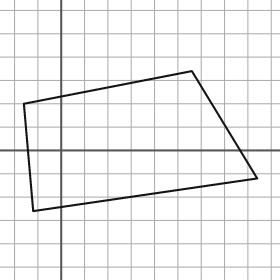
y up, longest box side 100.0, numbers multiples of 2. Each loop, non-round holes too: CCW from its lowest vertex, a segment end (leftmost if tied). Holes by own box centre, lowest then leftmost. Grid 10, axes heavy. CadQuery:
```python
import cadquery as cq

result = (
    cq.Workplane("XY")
    .moveTo(-12.0, -26.0)
    .lineTo(84.0, -12.0)
    .lineTo(56.0, 34.0)
    .lineTo(-16.0, 20.0)
    .close()
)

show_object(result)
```